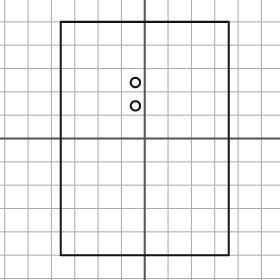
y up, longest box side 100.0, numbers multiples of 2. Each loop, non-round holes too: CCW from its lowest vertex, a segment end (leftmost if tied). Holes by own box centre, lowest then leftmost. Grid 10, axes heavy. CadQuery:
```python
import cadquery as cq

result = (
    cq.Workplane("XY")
    .moveTo(-36.0, -50.0)
    .lineTo(36.0, -50.0)
    .lineTo(36.0, 50.0)
    .lineTo(-36.0, 50.0)
    .close()
    .moveTo(-4.0, 14.0)
    .circle(2.0)
    .moveTo(-4.0, 24.0)
    .circle(2.0)
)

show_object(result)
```